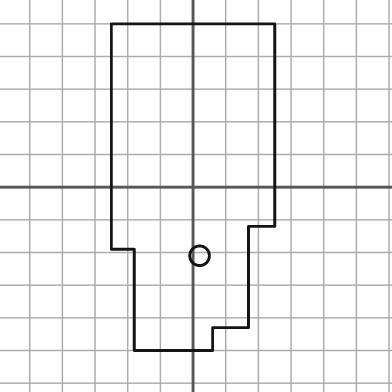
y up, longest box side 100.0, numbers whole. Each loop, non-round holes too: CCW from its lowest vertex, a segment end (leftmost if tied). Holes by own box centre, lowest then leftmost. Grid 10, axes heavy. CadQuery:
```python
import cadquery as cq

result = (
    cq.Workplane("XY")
    .moveTo(-18.0, -50.0)
    .lineTo(6.0, -50.0)
    .lineTo(6.0, -43.0)
    .lineTo(17.0, -43.0)
    .lineTo(17.0, -12.0)
    .lineTo(25.0, -12.0)
    .lineTo(25.0, 50.0)
    .lineTo(-25.0, 50.0)
    .lineTo(-25.0, -19.0)
    .lineTo(-18.0, -19.0)
    .close()
    .moveTo(2.0, -21.0)
    .circle(3.0)
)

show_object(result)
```